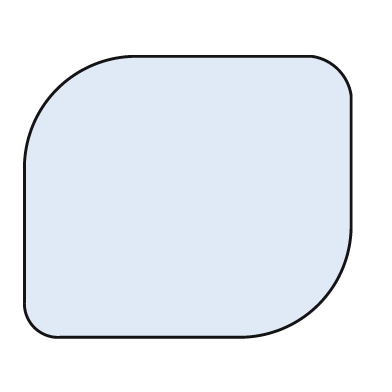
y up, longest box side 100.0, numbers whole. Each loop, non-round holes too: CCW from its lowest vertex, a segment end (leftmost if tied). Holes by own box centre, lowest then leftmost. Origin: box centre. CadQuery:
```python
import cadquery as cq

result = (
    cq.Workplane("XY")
    .moveTo(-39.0, -43.0)
    .lineTo(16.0, -43.0)
    .threePointArc((40.0, -33.0), (50.0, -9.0))
    .lineTo(50.0, 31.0)
    .threePointArc((46.0, 39.0), (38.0, 43.0))
    .lineTo(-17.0, 43.0)
    .threePointArc((-40.0, 33.0), (-50.0, 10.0))
    .lineTo(-50.0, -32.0)
    .threePointArc((-47.0, -40.0), (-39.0, -43.0))
    .close()
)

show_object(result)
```